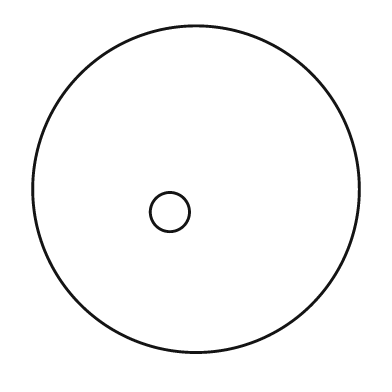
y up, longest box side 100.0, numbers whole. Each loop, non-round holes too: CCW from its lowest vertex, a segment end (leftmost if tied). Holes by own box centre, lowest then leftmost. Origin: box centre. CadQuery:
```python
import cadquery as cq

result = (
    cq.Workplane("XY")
    .moveTo(0.0, 0.0)
    .circle(50.0)
    .moveTo(-8.0, -7.0)
    .circle(6.0)
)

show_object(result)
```